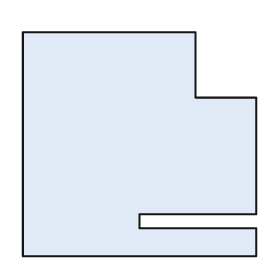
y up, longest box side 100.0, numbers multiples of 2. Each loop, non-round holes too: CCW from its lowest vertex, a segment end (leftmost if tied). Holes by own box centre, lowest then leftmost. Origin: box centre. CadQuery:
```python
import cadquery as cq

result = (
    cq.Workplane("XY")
    .moveTo(-50.0, -48.0)
    .lineTo(50.0, -48.0)
    .lineTo(50.0, -36.0)
    .lineTo(0.0, -36.0)
    .lineTo(0.0, -30.0)
    .lineTo(50.0, -30.0)
    .lineTo(50.0, 20.0)
    .lineTo(24.0, 20.0)
    .lineTo(24.0, 48.0)
    .lineTo(-50.0, 48.0)
    .close()
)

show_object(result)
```